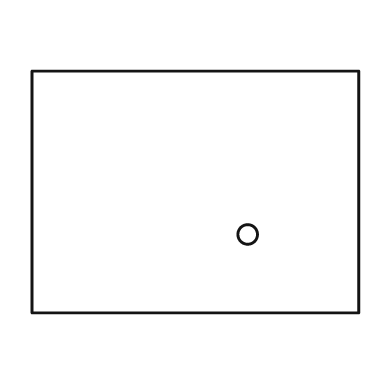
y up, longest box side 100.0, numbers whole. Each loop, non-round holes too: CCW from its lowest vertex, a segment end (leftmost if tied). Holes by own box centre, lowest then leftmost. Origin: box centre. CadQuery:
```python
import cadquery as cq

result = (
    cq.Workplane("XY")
    .moveTo(-50.0, -37.0)
    .lineTo(50.0, -37.0)
    .lineTo(50.0, 37.0)
    .lineTo(-50.0, 37.0)
    .close()
    .moveTo(16.0, -13.0)
    .circle(3.0)
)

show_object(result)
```